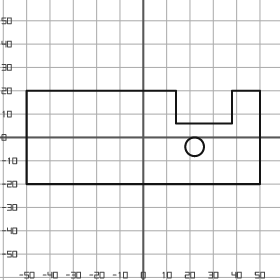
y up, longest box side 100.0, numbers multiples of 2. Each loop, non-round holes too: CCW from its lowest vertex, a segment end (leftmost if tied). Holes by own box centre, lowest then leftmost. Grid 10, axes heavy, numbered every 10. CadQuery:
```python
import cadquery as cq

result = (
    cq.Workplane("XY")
    .moveTo(-50.0, -20.0)
    .lineTo(50.0, -20.0)
    .lineTo(50.0, 20.0)
    .lineTo(38.0, 20.0)
    .lineTo(38.0, 6.0)
    .lineTo(14.0, 6.0)
    .lineTo(14.0, 20.0)
    .lineTo(-50.0, 20.0)
    .close()
    .moveTo(22.0, -4.0)
    .circle(4.0)
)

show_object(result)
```